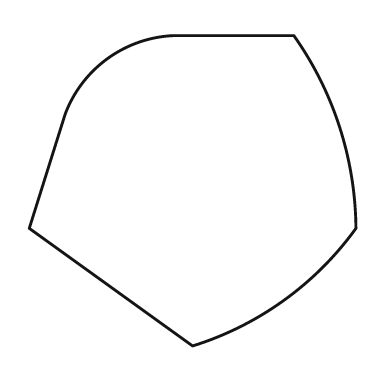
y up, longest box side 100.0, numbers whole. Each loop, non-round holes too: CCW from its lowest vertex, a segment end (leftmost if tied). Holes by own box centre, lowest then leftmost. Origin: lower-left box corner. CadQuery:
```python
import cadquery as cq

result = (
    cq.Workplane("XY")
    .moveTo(50.0, 0.0)
    .threePointArc((78.0, 14.0), (100.0, 36.0))
    .threePointArc((95.0, 67.0), (81.0, 95.0))
    .lineTo(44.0, 95.0)
    .threePointArc((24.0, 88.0), (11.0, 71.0))
    .lineTo(0.0, 36.0)
    .close()
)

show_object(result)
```